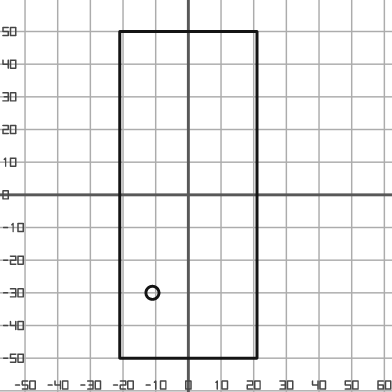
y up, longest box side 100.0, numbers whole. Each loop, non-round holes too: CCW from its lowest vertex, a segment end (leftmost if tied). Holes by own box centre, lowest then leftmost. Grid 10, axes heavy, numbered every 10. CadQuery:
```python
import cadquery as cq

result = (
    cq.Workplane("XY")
    .moveTo(-21.0, -50.0)
    .lineTo(21.0, -50.0)
    .lineTo(21.0, 50.0)
    .lineTo(-21.0, 50.0)
    .close()
    .moveTo(-11.0, -30.0)
    .circle(2.0)
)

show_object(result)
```